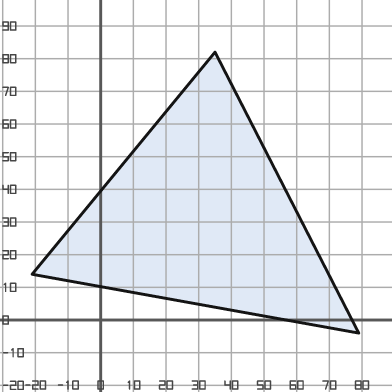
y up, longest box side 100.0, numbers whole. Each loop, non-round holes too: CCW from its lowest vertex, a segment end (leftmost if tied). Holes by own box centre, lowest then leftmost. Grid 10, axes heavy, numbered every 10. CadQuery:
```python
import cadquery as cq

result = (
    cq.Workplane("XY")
    .moveTo(79.0, -4.0)
    .lineTo(35.0, 82.0)
    .lineTo(-21.0, 14.0)
    .close()
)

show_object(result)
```